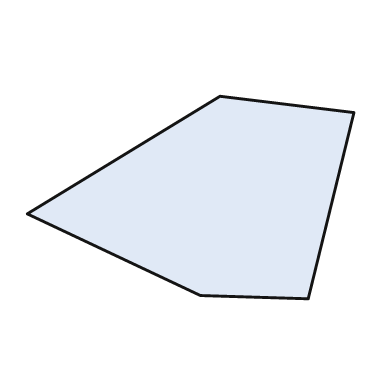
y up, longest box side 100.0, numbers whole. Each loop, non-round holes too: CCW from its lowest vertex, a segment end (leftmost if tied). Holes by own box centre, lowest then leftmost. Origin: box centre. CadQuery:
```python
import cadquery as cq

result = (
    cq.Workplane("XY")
    .moveTo(36.0, -31.0)
    .lineTo(50.0, 26.0)
    .lineTo(9.0, 31.0)
    .lineTo(-50.0, -5.0)
    .lineTo(3.0, -30.0)
    .close()
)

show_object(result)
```